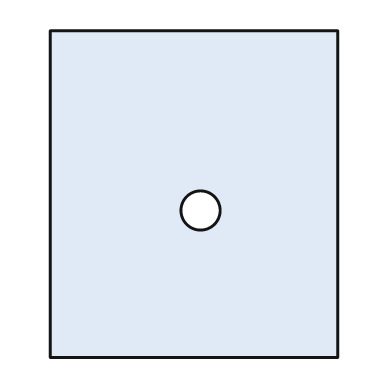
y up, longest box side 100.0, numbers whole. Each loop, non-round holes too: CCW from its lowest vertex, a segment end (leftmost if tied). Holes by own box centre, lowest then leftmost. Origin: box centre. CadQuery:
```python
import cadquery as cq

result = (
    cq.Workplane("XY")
    .moveTo(-44.0, -50.0)
    .lineTo(44.0, -50.0)
    .lineTo(44.0, 50.0)
    .lineTo(-44.0, 50.0)
    .close()
    .moveTo(2.0, -5.0)
    .circle(6.0)
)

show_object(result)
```